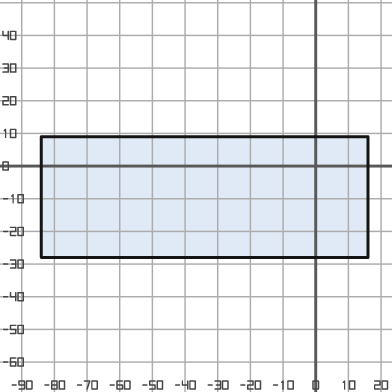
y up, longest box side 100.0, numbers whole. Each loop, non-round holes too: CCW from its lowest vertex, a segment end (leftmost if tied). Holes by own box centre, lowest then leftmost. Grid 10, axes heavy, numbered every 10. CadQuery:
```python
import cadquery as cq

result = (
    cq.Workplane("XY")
    .moveTo(-84.0, -28.0)
    .lineTo(16.0, -28.0)
    .lineTo(16.0, 9.0)
    .lineTo(-84.0, 9.0)
    .close()
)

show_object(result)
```